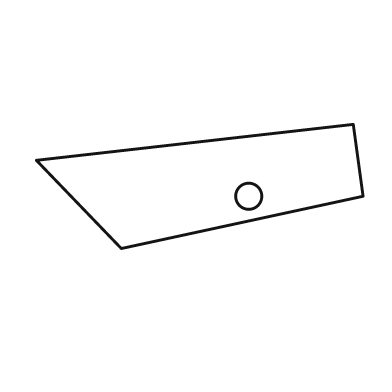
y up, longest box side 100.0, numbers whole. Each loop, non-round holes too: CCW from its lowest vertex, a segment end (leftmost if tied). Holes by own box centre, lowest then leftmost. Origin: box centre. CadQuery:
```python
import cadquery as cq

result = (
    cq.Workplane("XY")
    .moveTo(-24.0, -19.0)
    .lineTo(50.0, -3.0)
    .lineTo(47.0, 19.0)
    .lineTo(-50.0, 8.0)
    .close()
    .moveTo(15.0, -3.0)
    .circle(4.0)
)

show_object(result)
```